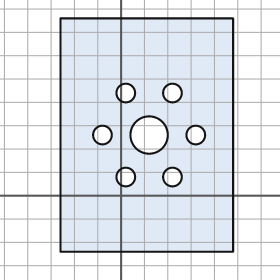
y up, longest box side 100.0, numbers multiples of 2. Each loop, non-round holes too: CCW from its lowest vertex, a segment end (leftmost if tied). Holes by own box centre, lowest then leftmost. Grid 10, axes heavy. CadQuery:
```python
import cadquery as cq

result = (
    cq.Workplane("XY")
    .moveTo(-26.0, -24.0)
    .lineTo(48.0, -24.0)
    .lineTo(48.0, 76.0)
    .lineTo(-26.0, 76.0)
    .close()
    .moveTo(2.0, 8.0)
    .circle(4.0)
    .moveTo(22.0, 8.0)
    .circle(4.0)
    .moveTo(-8.0, 26.0)
    .circle(4.0)
    .moveTo(12.0, 26.0)
    .circle(8.0)
    .moveTo(32.0, 26.0)
    .circle(4.0)
    .moveTo(2.0, 44.0)
    .circle(4.0)
    .moveTo(22.0, 44.0)
    .circle(4.0)
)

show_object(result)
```